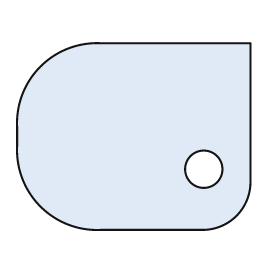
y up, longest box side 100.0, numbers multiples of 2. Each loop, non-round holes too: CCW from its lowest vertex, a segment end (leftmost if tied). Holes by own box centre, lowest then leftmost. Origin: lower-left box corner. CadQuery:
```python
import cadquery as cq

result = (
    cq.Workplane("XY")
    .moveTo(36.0, 0.0)
    .lineTo(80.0, 0.0)
    .threePointArc((94.0, 6.0), (100.0, 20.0))
    .lineTo(100.0, 80.0)
    .lineTo(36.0, 80.0)
    .threePointArc((10.0, 70.0), (0.0, 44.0))
    .lineTo(0.0, 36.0)
    .threePointArc((10.0, 10.0), (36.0, 0.0))
    .close()
    .moveTo(80.0, 26.0)
    .circle(8.0)
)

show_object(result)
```